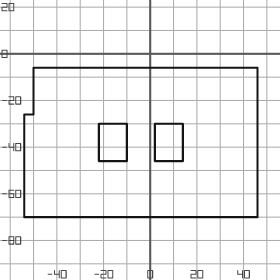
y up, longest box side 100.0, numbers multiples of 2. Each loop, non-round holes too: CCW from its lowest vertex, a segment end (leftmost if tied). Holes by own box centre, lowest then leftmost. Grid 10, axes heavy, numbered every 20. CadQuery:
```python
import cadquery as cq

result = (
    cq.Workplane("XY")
    .moveTo(-54.0, -70.0)
    .lineTo(46.0, -70.0)
    .lineTo(46.0, -6.0)
    .lineTo(-50.0, -6.0)
    .lineTo(-50.0, -26.0)
    .lineTo(-54.0, -26.0)
    .close()
    .moveTo(-22.0, -46.0)
    .lineTo(-10.0, -46.0)
    .lineTo(-10.0, -30.0)
    .lineTo(-22.0, -30.0)
    .close()
    .moveTo(2.0, -46.0)
    .lineTo(14.0, -46.0)
    .lineTo(14.0, -30.0)
    .lineTo(2.0, -30.0)
    .close()
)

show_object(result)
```